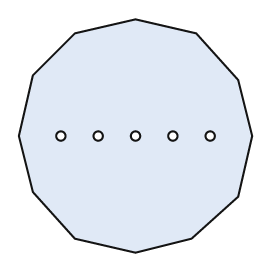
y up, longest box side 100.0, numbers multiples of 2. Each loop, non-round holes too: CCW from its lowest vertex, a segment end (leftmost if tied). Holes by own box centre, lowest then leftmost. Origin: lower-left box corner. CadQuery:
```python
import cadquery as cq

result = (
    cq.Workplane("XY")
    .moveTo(50.0, 0.0)
    .lineTo(74.0, 6.0)
    .lineTo(94.0, 24.0)
    .lineTo(100.0, 50.0)
    .lineTo(94.0, 74.0)
    .lineTo(76.0, 94.0)
    .lineTo(50.0, 100.0)
    .lineTo(24.0, 94.0)
    .lineTo(6.0, 76.0)
    .lineTo(0.0, 50.0)
    .lineTo(6.0, 26.0)
    .lineTo(24.0, 6.0)
    .close()
    .moveTo(18.0, 50.0)
    .circle(2.0)
    .moveTo(34.0, 50.0)
    .circle(2.0)
    .moveTo(50.0, 50.0)
    .circle(2.0)
    .moveTo(66.0, 50.0)
    .circle(2.0)
    .moveTo(82.0, 50.0)
    .circle(2.0)
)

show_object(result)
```